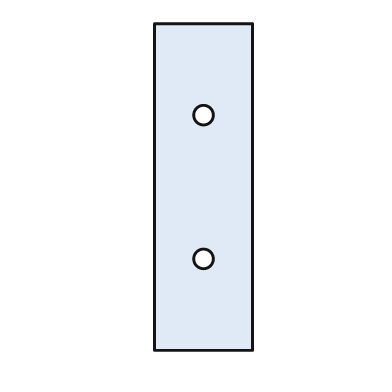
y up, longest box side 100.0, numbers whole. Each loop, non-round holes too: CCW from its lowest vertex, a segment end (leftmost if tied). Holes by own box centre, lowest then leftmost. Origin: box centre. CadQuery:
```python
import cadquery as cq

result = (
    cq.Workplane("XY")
    .moveTo(-15.0, -50.0)
    .lineTo(15.0, -50.0)
    .lineTo(15.0, 50.0)
    .lineTo(-15.0, 50.0)
    .close()
    .moveTo(0.0, -22.0)
    .circle(3.0)
    .moveTo(0.0, 22.0)
    .circle(3.0)
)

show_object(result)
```